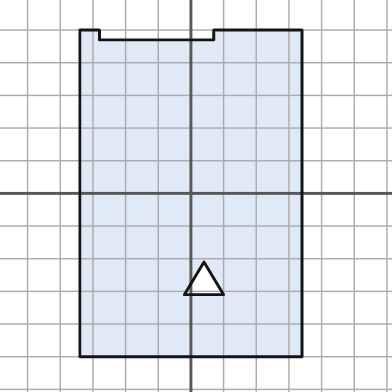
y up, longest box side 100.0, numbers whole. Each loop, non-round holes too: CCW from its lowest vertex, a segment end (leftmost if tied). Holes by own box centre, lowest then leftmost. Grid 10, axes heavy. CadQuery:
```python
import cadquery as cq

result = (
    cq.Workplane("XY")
    .moveTo(-34.0, -50.0)
    .lineTo(34.0, -50.0)
    .lineTo(34.0, 50.0)
    .lineTo(7.0, 50.0)
    .lineTo(7.0, 47.0)
    .lineTo(-28.0, 47.0)
    .lineTo(-28.0, 50.0)
    .lineTo(-34.0, 50.0)
    .close()
    .moveTo(-2.0, -31.0)
    .lineTo(10.0, -31.0)
    .lineTo(4.0, -21.0)
    .close()
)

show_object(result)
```